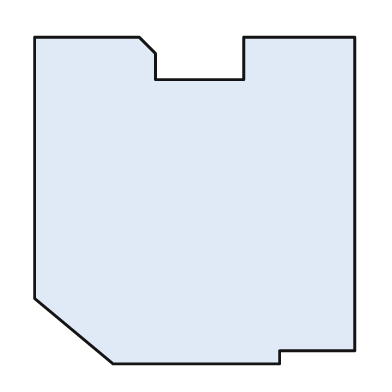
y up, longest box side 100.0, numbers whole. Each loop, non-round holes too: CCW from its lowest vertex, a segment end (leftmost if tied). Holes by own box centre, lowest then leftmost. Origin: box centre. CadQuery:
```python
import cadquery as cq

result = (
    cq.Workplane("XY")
    .moveTo(-25.0, -50.0)
    .lineTo(26.0, -50.0)
    .lineTo(26.0, -46.0)
    .lineTo(49.0, -46.0)
    .lineTo(49.0, 50.0)
    .lineTo(15.0, 50.0)
    .lineTo(15.0, 37.0)
    .lineTo(-12.0, 37.0)
    .lineTo(-12.0, 45.0)
    .lineTo(-17.0, 50.0)
    .lineTo(-49.0, 50.0)
    .lineTo(-49.0, -30.0)
    .close()
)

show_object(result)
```